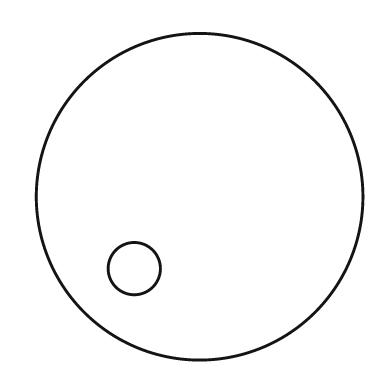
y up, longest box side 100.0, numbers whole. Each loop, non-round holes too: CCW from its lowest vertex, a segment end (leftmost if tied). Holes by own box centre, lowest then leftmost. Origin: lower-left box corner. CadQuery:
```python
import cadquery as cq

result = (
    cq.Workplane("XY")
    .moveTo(50.0, 50.0)
    .circle(50.0)
    .moveTo(30.0, 28.0)
    .circle(8.0)
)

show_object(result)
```